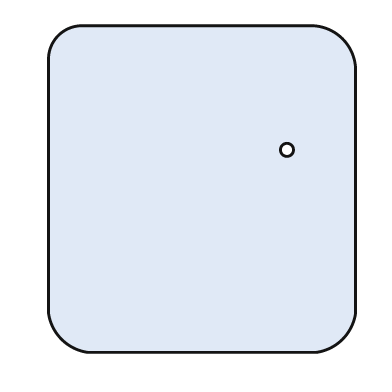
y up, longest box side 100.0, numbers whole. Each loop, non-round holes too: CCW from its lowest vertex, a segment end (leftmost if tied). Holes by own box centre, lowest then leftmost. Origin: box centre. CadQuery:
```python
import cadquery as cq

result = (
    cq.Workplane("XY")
    .moveTo(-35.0, -50.0)
    .lineTo(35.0, -50.0)
    .threePointArc((43.0, -46.0), (47.0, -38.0))
    .lineTo(47.0, 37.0)
    .threePointArc((43.0, 46.0), (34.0, 50.0))
    .lineTo(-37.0, 50.0)
    .threePointArc((-44.0, 47.0), (-47.0, 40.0))
    .lineTo(-47.0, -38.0)
    .threePointArc((-43.0, -46.0), (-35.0, -50.0))
    .close()
    .moveTo(26.0, 12.0)
    .circle(2.0)
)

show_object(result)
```